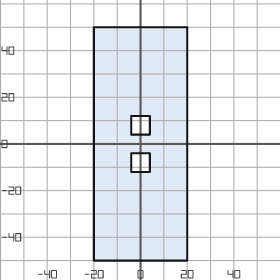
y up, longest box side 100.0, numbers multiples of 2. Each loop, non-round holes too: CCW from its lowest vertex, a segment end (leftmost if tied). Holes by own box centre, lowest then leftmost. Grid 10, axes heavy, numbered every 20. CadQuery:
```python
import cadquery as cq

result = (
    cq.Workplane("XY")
    .moveTo(-20.0, -50.0)
    .lineTo(20.0, -50.0)
    .lineTo(20.0, 50.0)
    .lineTo(-20.0, 50.0)
    .close()
    .moveTo(-4.0, -12.0)
    .lineTo(4.0, -12.0)
    .lineTo(4.0, -4.0)
    .lineTo(-4.0, -4.0)
    .close()
    .moveTo(-4.0, 4.0)
    .lineTo(4.0, 4.0)
    .lineTo(4.0, 12.0)
    .lineTo(-4.0, 12.0)
    .close()
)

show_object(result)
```